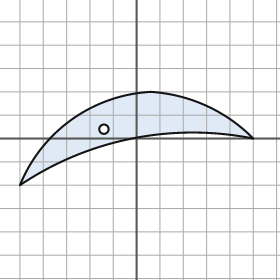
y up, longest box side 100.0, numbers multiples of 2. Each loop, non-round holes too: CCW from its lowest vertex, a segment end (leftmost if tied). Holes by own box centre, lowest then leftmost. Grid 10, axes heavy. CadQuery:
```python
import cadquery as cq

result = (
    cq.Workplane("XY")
    .moveTo(-50.0, -20.0)
    .threePointArc((-2.0, 0.0), (50.0, 0.0))
    .threePointArc((30.0, 14.0), (6.0, 20.0))
    .threePointArc((-28.0, 8.0), (-50.0, -20.0))
    .close()
    .moveTo(-14.0, 4.0)
    .circle(2.0)
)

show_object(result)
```